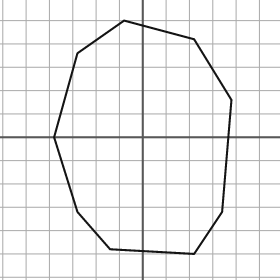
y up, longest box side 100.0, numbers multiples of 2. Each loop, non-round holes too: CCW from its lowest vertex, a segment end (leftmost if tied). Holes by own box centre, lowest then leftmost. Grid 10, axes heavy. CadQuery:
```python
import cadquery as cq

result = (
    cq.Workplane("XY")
    .moveTo(22.0, -50.0)
    .lineTo(34.0, -32.0)
    .lineTo(38.0, 16.0)
    .lineTo(22.0, 42.0)
    .lineTo(-8.0, 50.0)
    .lineTo(-28.0, 36.0)
    .lineTo(-38.0, 0.0)
    .lineTo(-28.0, -32.0)
    .lineTo(-14.0, -48.0)
    .close()
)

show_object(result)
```